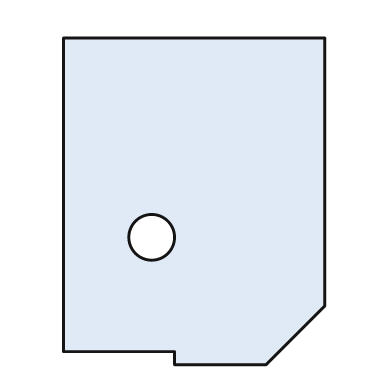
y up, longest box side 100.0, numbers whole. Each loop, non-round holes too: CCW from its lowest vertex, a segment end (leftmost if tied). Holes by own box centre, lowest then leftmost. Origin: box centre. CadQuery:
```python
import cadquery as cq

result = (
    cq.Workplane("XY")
    .moveTo(-6.0, -50.0)
    .lineTo(22.0, -50.0)
    .lineTo(40.0, -32.0)
    .lineTo(40.0, 50.0)
    .lineTo(-40.0, 50.0)
    .lineTo(-40.0, -46.0)
    .lineTo(-6.0, -46.0)
    .close()
    .moveTo(-13.0, -11.0)
    .circle(7.0)
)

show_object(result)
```